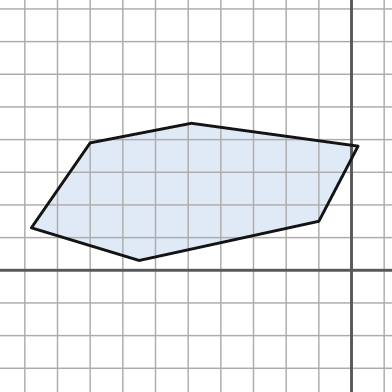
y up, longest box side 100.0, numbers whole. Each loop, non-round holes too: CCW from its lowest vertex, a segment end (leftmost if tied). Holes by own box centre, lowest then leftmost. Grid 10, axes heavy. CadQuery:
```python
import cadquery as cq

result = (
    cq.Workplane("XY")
    .moveTo(-65.0, 3.0)
    .lineTo(-10.0, 15.0)
    .lineTo(2.0, 38.0)
    .lineTo(-49.0, 45.0)
    .lineTo(-80.0, 39.0)
    .lineTo(-98.0, 13.0)
    .close()
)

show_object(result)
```